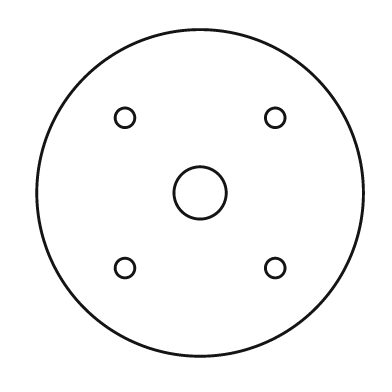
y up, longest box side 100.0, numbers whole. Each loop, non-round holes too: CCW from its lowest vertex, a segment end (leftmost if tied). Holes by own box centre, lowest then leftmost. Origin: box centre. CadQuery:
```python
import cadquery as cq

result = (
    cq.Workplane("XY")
    .moveTo(0.0, 0.0)
    .circle(50.0)
    .moveTo(-23.0, -23.0)
    .circle(3.0)
    .moveTo(23.0, -23.0)
    .circle(3.0)
    .moveTo(0.0, 0.0)
    .circle(8.0)
    .moveTo(-23.0, 23.0)
    .circle(3.0)
    .moveTo(23.0, 23.0)
    .circle(3.0)
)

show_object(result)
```